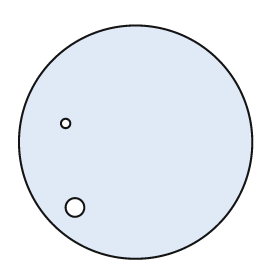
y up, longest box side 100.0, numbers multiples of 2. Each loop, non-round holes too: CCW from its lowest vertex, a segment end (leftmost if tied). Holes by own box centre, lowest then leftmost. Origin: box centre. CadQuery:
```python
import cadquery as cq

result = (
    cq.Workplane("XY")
    .moveTo(0.0, 0.0)
    .circle(50.0)
    .moveTo(-26.0, -28.0)
    .circle(4.0)
    .moveTo(-30.0, 8.0)
    .circle(2.0)
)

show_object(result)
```